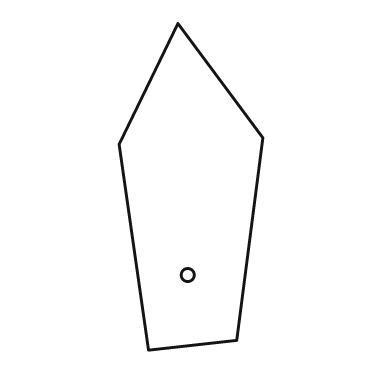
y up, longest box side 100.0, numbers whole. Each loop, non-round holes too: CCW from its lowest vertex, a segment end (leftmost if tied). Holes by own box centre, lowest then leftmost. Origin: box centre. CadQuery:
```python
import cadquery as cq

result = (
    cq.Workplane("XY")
    .moveTo(-13.0, -50.0)
    .lineTo(14.0, -47.0)
    .lineTo(22.0, 15.0)
    .lineTo(-4.0, 50.0)
    .lineTo(-22.0, 13.0)
    .close()
    .moveTo(-1.0, -27.0)
    .circle(2.0)
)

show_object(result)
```